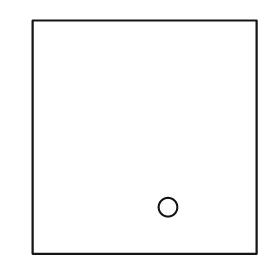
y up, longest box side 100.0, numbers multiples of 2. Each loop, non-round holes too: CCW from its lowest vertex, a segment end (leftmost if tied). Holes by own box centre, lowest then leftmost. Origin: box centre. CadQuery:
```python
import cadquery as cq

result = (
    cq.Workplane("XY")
    .moveTo(-48.0, -50.0)
    .lineTo(48.0, -50.0)
    .lineTo(48.0, 50.0)
    .lineTo(-48.0, 50.0)
    .close()
    .moveTo(10.0, -30.0)
    .circle(4.0)
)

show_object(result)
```